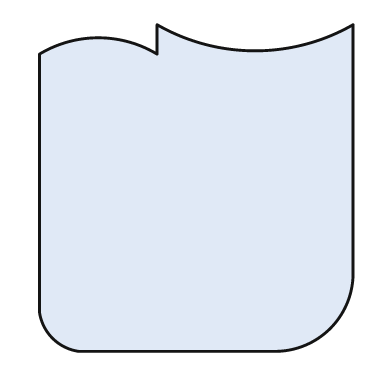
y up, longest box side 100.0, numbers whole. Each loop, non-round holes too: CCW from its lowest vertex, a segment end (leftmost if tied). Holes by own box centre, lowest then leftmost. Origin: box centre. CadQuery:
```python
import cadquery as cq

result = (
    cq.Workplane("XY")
    .moveTo(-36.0, -50.0)
    .lineTo(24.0, -50.0)
    .threePointArc((41.0, -43.0), (48.0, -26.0))
    .lineTo(48.0, 50.0)
    .threePointArc((18.0, 42.0), (-12.0, 50.0))
    .lineTo(-12.0, 41.0)
    .threePointArc((-30.0, 46.0), (-48.0, 41.0))
    .lineTo(-48.0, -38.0)
    .threePointArc((-44.0, -46.0), (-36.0, -50.0))
    .close()
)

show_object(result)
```